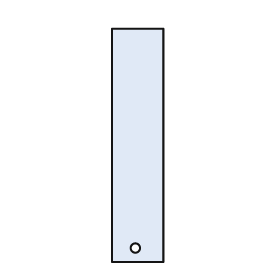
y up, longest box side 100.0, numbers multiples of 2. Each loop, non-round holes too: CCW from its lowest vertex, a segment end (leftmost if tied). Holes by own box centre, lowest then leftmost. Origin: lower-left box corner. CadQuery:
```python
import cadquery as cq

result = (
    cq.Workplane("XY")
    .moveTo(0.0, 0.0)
    .lineTo(22.0, 0.0)
    .lineTo(22.0, 100.0)
    .lineTo(0.0, 100.0)
    .close()
    .moveTo(10.0, 6.0)
    .circle(2.0)
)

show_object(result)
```